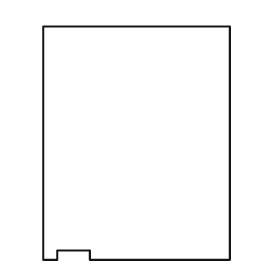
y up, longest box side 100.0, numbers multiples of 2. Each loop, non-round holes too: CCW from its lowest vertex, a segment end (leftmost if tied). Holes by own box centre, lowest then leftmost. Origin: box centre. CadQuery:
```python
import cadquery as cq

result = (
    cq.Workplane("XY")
    .moveTo(-40.0, -50.0)
    .lineTo(-34.0, -50.0)
    .lineTo(-34.0, -46.0)
    .lineTo(-20.0, -46.0)
    .lineTo(-20.0, -50.0)
    .lineTo(40.0, -50.0)
    .lineTo(40.0, 50.0)
    .lineTo(-40.0, 50.0)
    .close()
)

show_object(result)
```